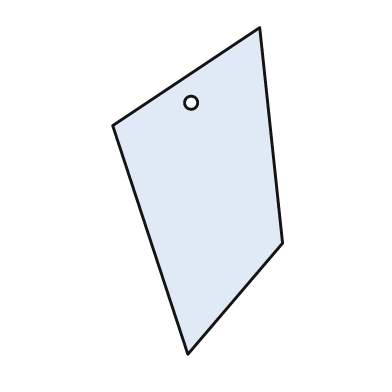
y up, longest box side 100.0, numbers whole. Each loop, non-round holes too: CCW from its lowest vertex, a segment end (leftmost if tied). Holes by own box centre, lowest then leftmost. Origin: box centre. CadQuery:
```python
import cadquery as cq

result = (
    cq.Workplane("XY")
    .moveTo(-3.0, -50.0)
    .lineTo(26.0, -16.0)
    .lineTo(19.0, 50.0)
    .lineTo(-26.0, 20.0)
    .close()
    .moveTo(-2.0, 27.0)
    .circle(2.0)
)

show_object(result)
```